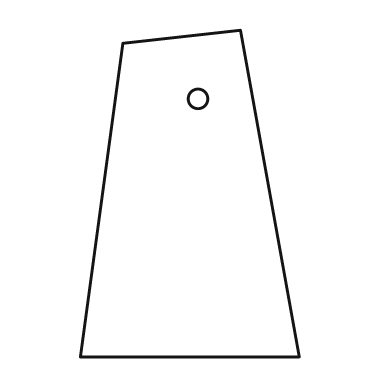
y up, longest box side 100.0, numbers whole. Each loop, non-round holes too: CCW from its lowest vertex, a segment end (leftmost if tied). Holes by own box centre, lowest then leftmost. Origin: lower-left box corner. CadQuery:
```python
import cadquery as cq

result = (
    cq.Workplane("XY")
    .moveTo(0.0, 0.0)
    .lineTo(67.0, 0.0)
    .lineTo(49.0, 100.0)
    .lineTo(13.0, 96.0)
    .close()
    .moveTo(36.0, 79.0)
    .circle(3.0)
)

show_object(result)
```